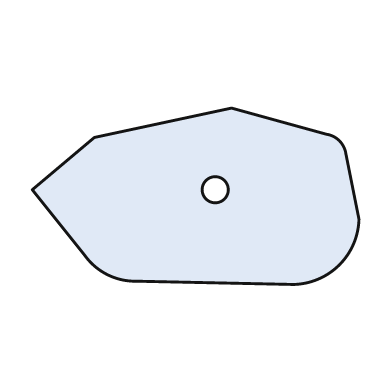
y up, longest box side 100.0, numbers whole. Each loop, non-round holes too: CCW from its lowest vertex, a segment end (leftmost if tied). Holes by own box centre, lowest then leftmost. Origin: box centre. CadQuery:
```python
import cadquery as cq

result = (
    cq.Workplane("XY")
    .moveTo(30.0, -27.0)
    .threePointArc((44.0, -21.0), (50.0, -7.0))
    .lineTo(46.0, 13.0)
    .threePointArc((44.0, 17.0), (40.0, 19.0))
    .lineTo(11.0, 27.0)
    .lineTo(-31.0, 18.0)
    .lineTo(-50.0, 2.0)
    .lineTo(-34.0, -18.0)
    .threePointArc((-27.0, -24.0), (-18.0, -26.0))
    .close()
    .moveTo(6.0, 2.0)
    .circle(4.0)
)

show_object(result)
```